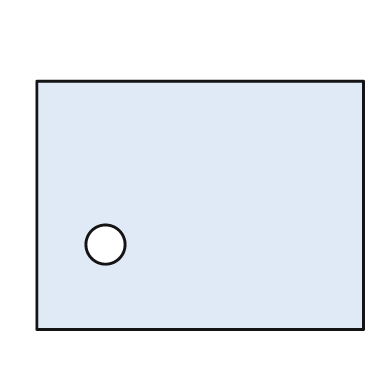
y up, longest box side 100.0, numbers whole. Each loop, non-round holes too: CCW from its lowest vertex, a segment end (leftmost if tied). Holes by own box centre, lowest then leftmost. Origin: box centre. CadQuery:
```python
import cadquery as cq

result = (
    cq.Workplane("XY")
    .moveTo(-50.0, -38.0)
    .lineTo(50.0, -38.0)
    .lineTo(50.0, 38.0)
    .lineTo(-50.0, 38.0)
    .close()
    .moveTo(-29.0, -12.0)
    .circle(6.0)
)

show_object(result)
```